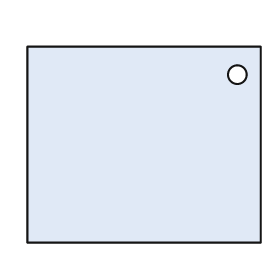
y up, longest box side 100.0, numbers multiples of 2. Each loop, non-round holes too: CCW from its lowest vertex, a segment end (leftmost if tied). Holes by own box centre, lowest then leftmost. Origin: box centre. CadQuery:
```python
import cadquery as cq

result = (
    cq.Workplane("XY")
    .moveTo(-50.0, -42.0)
    .lineTo(50.0, -42.0)
    .lineTo(50.0, 42.0)
    .lineTo(-50.0, 42.0)
    .close()
    .moveTo(40.0, 30.0)
    .circle(4.0)
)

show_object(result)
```